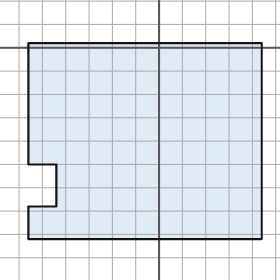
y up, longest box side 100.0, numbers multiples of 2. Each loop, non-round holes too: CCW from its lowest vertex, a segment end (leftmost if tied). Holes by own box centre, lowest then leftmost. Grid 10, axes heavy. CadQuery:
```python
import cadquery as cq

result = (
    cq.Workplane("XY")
    .moveTo(-56.0, -82.0)
    .lineTo(44.0, -82.0)
    .lineTo(44.0, 2.0)
    .lineTo(-56.0, 2.0)
    .lineTo(-56.0, -50.0)
    .lineTo(-44.0, -50.0)
    .lineTo(-44.0, -68.0)
    .lineTo(-56.0, -68.0)
    .close()
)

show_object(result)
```